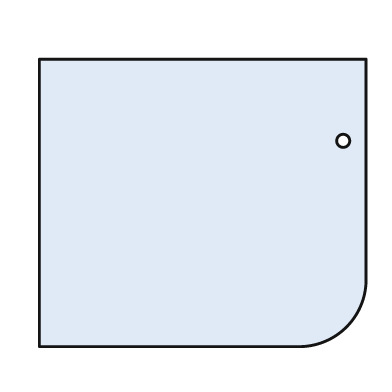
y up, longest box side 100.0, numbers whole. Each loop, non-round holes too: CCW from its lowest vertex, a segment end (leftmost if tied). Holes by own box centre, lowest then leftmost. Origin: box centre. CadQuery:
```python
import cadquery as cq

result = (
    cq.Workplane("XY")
    .moveTo(-50.0, -44.0)
    .lineTo(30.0, -44.0)
    .threePointArc((44.0, -38.0), (50.0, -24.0))
    .lineTo(50.0, 44.0)
    .lineTo(-50.0, 44.0)
    .close()
    .moveTo(43.0, 19.0)
    .circle(2.0)
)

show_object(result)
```